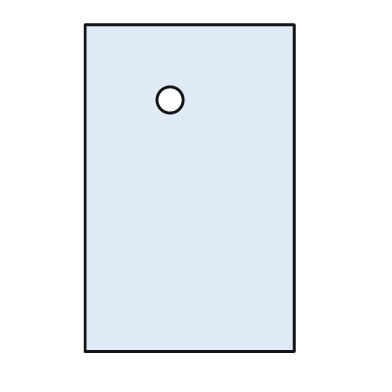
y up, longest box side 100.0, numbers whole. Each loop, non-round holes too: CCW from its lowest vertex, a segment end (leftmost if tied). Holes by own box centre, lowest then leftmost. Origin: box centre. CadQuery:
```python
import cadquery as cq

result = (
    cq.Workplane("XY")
    .moveTo(-32.0, -50.0)
    .lineTo(32.0, -50.0)
    .lineTo(32.0, 50.0)
    .lineTo(-32.0, 50.0)
    .close()
    .moveTo(-6.0, 27.0)
    .circle(4.0)
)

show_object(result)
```